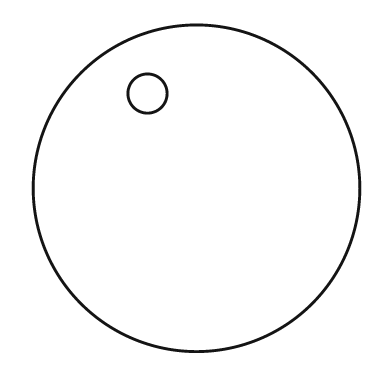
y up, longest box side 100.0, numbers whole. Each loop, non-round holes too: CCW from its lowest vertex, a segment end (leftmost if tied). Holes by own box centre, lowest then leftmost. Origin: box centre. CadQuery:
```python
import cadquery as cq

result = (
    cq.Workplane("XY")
    .moveTo(0.0, 0.0)
    .circle(50.0)
    .moveTo(-15.0, 29.0)
    .circle(6.0)
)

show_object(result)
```